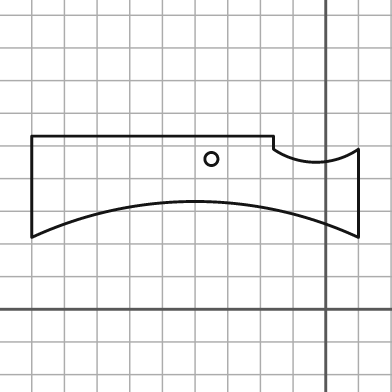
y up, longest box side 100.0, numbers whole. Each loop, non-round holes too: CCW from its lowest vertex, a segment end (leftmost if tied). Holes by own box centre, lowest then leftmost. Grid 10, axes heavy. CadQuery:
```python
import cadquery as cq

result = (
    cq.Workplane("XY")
    .moveTo(-90.0, 22.0)
    .threePointArc((-40.0, 33.0), (10.0, 22.0))
    .lineTo(10.0, 49.0)
    .threePointArc((-3.0, 45.0), (-16.0, 49.0))
    .lineTo(-16.0, 53.0)
    .lineTo(-90.0, 53.0)
    .close()
    .moveTo(-35.0, 46.0)
    .circle(2.0)
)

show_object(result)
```